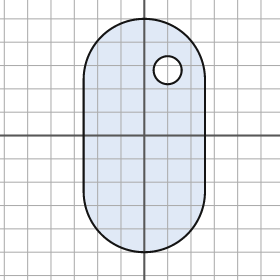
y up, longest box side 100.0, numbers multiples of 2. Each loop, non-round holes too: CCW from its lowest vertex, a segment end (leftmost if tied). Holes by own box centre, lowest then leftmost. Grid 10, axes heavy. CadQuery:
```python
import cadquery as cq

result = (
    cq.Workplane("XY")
    .moveTo(-26.0, -24.0)
    .threePointArc((0.0, -50.0), (26.0, -24.0))
    .lineTo(26.0, 24.0)
    .threePointArc((0.0, 50.0), (-26.0, 24.0))
    .close()
    .moveTo(10.0, 28.0)
    .circle(6.0)
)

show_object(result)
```